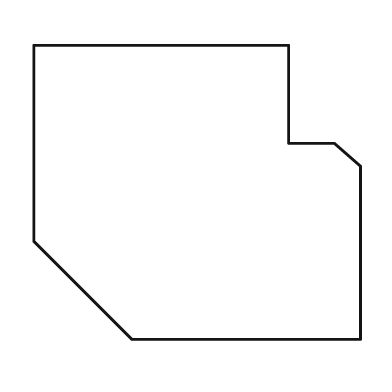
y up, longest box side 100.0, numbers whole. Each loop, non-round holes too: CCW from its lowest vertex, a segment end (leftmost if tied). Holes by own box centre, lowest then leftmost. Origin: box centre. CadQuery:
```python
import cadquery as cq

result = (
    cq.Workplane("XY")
    .moveTo(-20.0, -45.0)
    .lineTo(50.0, -45.0)
    .lineTo(50.0, 8.0)
    .lineTo(42.0, 15.0)
    .lineTo(28.0, 15.0)
    .lineTo(28.0, 45.0)
    .lineTo(-50.0, 45.0)
    .lineTo(-50.0, -15.0)
    .close()
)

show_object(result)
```